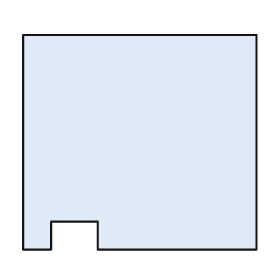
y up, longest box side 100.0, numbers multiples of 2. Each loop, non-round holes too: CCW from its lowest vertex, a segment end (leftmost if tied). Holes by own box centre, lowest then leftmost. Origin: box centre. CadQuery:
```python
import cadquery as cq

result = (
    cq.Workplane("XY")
    .moveTo(-50.0, -46.0)
    .lineTo(-38.0, -46.0)
    .lineTo(-38.0, -34.0)
    .lineTo(-18.0, -34.0)
    .lineTo(-18.0, -46.0)
    .lineTo(50.0, -46.0)
    .lineTo(50.0, 46.0)
    .lineTo(-50.0, 46.0)
    .close()
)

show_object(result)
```